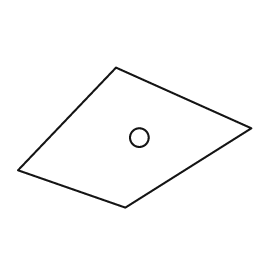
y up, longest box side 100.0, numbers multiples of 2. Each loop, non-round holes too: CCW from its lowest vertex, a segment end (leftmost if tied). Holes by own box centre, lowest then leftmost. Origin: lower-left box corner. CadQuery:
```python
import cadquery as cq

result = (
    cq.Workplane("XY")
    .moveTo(46.0, 0.0)
    .lineTo(100.0, 34.0)
    .lineTo(42.0, 60.0)
    .lineTo(0.0, 16.0)
    .close()
    .moveTo(52.0, 30.0)
    .circle(4.0)
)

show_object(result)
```